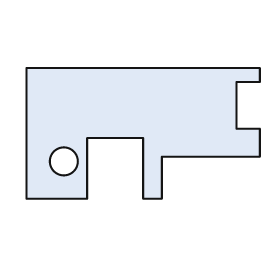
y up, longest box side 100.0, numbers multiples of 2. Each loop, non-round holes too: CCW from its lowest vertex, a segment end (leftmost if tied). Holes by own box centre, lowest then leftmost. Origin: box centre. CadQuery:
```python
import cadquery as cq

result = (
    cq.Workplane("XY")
    .moveTo(-50.0, -28.0)
    .lineTo(-24.0, -28.0)
    .lineTo(-24.0, -2.0)
    .lineTo(0.0, -2.0)
    .lineTo(0.0, -28.0)
    .lineTo(8.0, -28.0)
    .lineTo(8.0, -10.0)
    .lineTo(50.0, -10.0)
    .lineTo(50.0, 2.0)
    .lineTo(40.0, 2.0)
    .lineTo(40.0, 22.0)
    .lineTo(50.0, 22.0)
    .lineTo(50.0, 28.0)
    .lineTo(-50.0, 28.0)
    .close()
    .moveTo(-34.0, -12.0)
    .circle(6.0)
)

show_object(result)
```